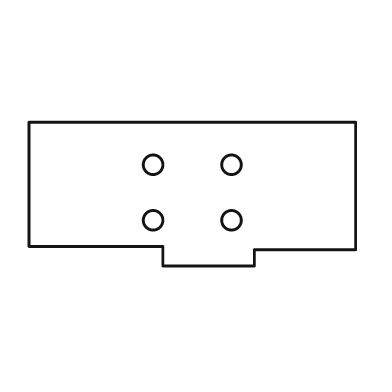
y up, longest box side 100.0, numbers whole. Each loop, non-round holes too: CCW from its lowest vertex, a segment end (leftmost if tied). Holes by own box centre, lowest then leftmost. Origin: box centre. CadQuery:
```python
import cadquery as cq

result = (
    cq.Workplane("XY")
    .moveTo(-9.0, -22.0)
    .lineTo(19.0, -22.0)
    .lineTo(19.0, -17.0)
    .lineTo(50.0, -17.0)
    .lineTo(50.0, 22.0)
    .lineTo(-50.0, 22.0)
    .lineTo(-50.0, -16.0)
    .lineTo(-9.0, -16.0)
    .close()
    .moveTo(-12.0, -8.0)
    .circle(3.0)
    .moveTo(12.0, -8.0)
    .circle(3.0)
    .moveTo(-12.0, 9.0)
    .circle(3.0)
    .moveTo(12.0, 9.0)
    .circle(3.0)
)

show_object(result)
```